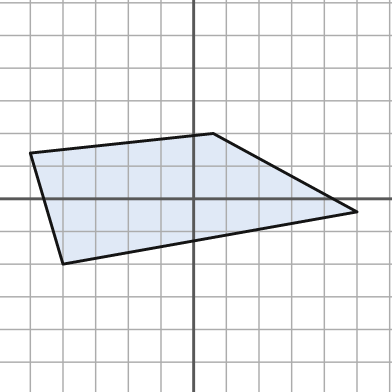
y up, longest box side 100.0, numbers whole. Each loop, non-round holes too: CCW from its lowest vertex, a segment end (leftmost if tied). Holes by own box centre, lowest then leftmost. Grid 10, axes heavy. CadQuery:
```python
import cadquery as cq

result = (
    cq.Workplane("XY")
    .moveTo(-40.0, -20.0)
    .lineTo(50.0, -4.0)
    .lineTo(6.0, 20.0)
    .lineTo(-50.0, 14.0)
    .close()
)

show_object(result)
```